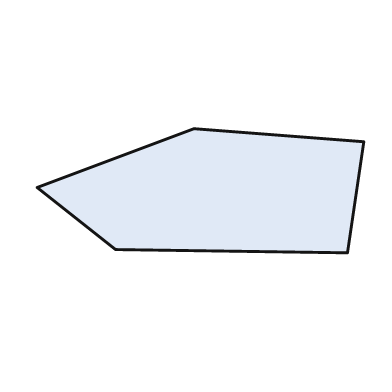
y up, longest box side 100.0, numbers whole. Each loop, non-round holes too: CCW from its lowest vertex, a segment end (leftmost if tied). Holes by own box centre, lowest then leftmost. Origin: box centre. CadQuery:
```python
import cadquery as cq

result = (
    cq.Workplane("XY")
    .moveTo(45.0, -19.0)
    .lineTo(50.0, 15.0)
    .lineTo(-2.0, 19.0)
    .lineTo(-50.0, 1.0)
    .lineTo(-26.0, -18.0)
    .close()
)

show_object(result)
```